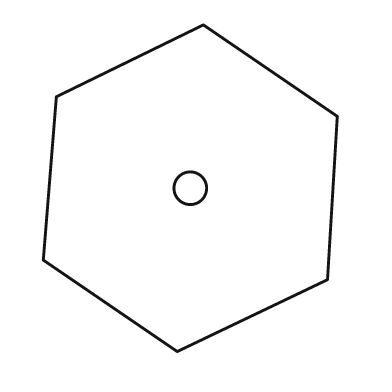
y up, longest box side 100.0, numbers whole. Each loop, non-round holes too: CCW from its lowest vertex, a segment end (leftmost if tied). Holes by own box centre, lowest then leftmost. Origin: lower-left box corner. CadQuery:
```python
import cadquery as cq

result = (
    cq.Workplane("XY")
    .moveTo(41.0, 0.0)
    .lineTo(87.0, 22.0)
    .lineTo(90.0, 72.0)
    .lineTo(49.0, 100.0)
    .lineTo(4.0, 78.0)
    .lineTo(0.0, 28.0)
    .close()
    .moveTo(45.0, 50.0)
    .circle(5.0)
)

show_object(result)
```